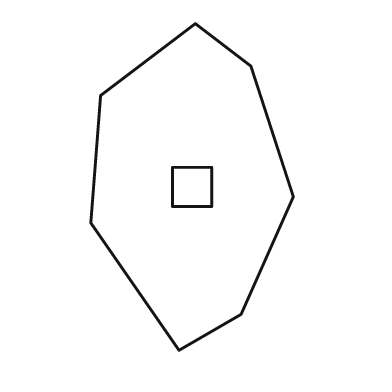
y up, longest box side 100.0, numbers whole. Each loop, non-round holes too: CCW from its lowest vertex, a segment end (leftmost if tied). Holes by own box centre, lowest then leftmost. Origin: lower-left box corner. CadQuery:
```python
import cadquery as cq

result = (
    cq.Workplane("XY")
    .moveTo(27.0, 0.0)
    .lineTo(46.0, 11.0)
    .lineTo(62.0, 47.0)
    .lineTo(49.0, 87.0)
    .lineTo(32.0, 100.0)
    .lineTo(3.0, 78.0)
    .lineTo(0.0, 39.0)
    .close()
    .moveTo(25.0, 44.0)
    .lineTo(37.0, 44.0)
    .lineTo(37.0, 56.0)
    .lineTo(25.0, 56.0)
    .close()
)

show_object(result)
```